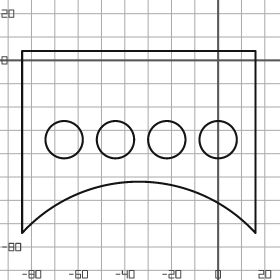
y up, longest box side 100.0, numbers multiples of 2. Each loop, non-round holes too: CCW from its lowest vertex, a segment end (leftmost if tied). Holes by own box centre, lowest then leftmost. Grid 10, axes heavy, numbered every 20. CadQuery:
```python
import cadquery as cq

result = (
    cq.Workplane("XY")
    .moveTo(-84.0, -74.0)
    .threePointArc((-34.0, -52.0), (16.0, -74.0))
    .lineTo(16.0, 4.0)
    .lineTo(-84.0, 4.0)
    .close()
    .moveTo(-66.0, -34.0)
    .circle(8.0)
    .moveTo(-44.0, -34.0)
    .circle(8.0)
    .moveTo(-22.0, -34.0)
    .circle(8.0)
    .moveTo(0.0, -34.0)
    .circle(8.0)
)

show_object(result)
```